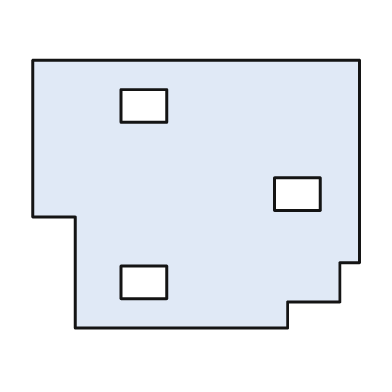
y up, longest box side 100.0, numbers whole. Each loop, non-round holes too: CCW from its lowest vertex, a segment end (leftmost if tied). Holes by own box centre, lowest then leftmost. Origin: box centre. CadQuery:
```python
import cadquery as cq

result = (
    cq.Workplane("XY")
    .moveTo(-37.0, -41.0)
    .lineTo(28.0, -41.0)
    .lineTo(28.0, -33.0)
    .lineTo(44.0, -33.0)
    .lineTo(44.0, -21.0)
    .lineTo(50.0, -21.0)
    .lineTo(50.0, 41.0)
    .lineTo(-50.0, 41.0)
    .lineTo(-50.0, -7.0)
    .lineTo(-37.0, -7.0)
    .close()
    .moveTo(-23.0, -32.0)
    .lineTo(-9.0, -32.0)
    .lineTo(-9.0, -22.0)
    .lineTo(-23.0, -22.0)
    .close()
    .moveTo(24.0, -5.0)
    .lineTo(38.0, -5.0)
    .lineTo(38.0, 5.0)
    .lineTo(24.0, 5.0)
    .close()
    .moveTo(-23.0, 22.0)
    .lineTo(-9.0, 22.0)
    .lineTo(-9.0, 32.0)
    .lineTo(-23.0, 32.0)
    .close()
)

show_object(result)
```